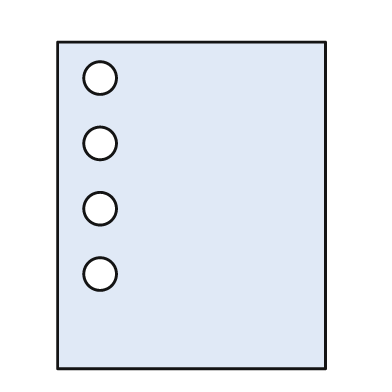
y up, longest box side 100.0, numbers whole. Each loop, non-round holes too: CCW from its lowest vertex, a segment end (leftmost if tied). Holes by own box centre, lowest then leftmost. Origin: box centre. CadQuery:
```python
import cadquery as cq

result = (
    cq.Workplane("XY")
    .moveTo(-41.0, -50.0)
    .lineTo(41.0, -50.0)
    .lineTo(41.0, 50.0)
    .lineTo(-41.0, 50.0)
    .close()
    .moveTo(-28.0, -21.0)
    .circle(5.0)
    .moveTo(-28.0, -1.0)
    .circle(5.0)
    .moveTo(-28.0, 19.0)
    .circle(5.0)
    .moveTo(-28.0, 39.0)
    .circle(5.0)
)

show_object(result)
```